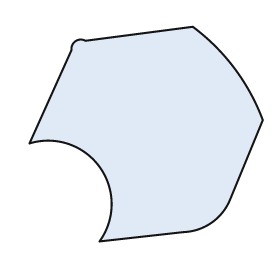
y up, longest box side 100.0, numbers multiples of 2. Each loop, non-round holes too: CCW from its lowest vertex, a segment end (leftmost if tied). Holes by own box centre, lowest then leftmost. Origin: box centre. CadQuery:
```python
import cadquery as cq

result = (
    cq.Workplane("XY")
    .moveTo(-20.0, -46.0)
    .lineTo(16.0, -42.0)
    .threePointArc((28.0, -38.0), (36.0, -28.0))
    .lineTo(50.0, 6.0)
    .threePointArc((38.0, 28.0), (20.0, 46.0))
    .lineTo(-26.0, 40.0)
    .threePointArc((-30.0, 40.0), (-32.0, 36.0))
    .lineTo(-50.0, -4.0)
    .threePointArc((-20.0, -14.0), (-20.0, -46.0))
    .close()
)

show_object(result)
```